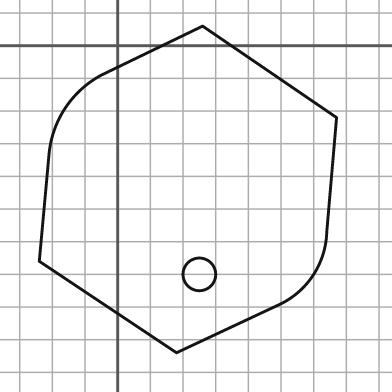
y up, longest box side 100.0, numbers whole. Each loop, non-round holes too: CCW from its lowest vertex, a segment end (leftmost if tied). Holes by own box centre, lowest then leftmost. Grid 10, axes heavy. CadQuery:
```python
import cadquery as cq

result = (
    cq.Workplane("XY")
    .moveTo(18.0, -94.0)
    .lineTo(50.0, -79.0)
    .threePointArc((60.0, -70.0), (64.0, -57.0))
    .lineTo(67.0, -22.0)
    .lineTo(26.0, 6.0)
    .lineTo(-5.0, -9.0)
    .threePointArc((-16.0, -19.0), (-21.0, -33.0))
    .lineTo(-24.0, -66.0)
    .close()
    .moveTo(25.0, -70.0)
    .circle(5.0)
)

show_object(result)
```